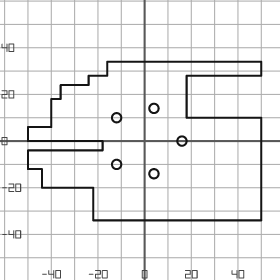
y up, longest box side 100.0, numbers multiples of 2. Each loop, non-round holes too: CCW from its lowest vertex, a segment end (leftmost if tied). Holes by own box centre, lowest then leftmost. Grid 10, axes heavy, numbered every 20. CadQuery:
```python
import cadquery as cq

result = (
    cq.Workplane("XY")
    .moveTo(-22.0, -34.0)
    .lineTo(50.0, -34.0)
    .lineTo(50.0, 10.0)
    .lineTo(18.0, 10.0)
    .lineTo(18.0, 28.0)
    .lineTo(50.0, 28.0)
    .lineTo(50.0, 34.0)
    .lineTo(-16.0, 34.0)
    .lineTo(-16.0, 28.0)
    .lineTo(-24.0, 28.0)
    .lineTo(-24.0, 24.0)
    .lineTo(-36.0, 24.0)
    .lineTo(-36.0, 18.0)
    .lineTo(-40.0, 18.0)
    .lineTo(-40.0, 6.0)
    .lineTo(-50.0, 6.0)
    .lineTo(-50.0, 0.0)
    .lineTo(-18.0, 0.0)
    .lineTo(-18.0, -4.0)
    .lineTo(-50.0, -4.0)
    .lineTo(-50.0, -12.0)
    .lineTo(-44.0, -12.0)
    .lineTo(-44.0, -20.0)
    .lineTo(-22.0, -20.0)
    .close()
    .moveTo(4.0, -14.0)
    .circle(2.0)
    .moveTo(-12.0, -10.0)
    .circle(2.0)
    .moveTo(16.0, 0.0)
    .circle(2.0)
    .moveTo(-12.0, 10.0)
    .circle(2.0)
    .moveTo(4.0, 14.0)
    .circle(2.0)
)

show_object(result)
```